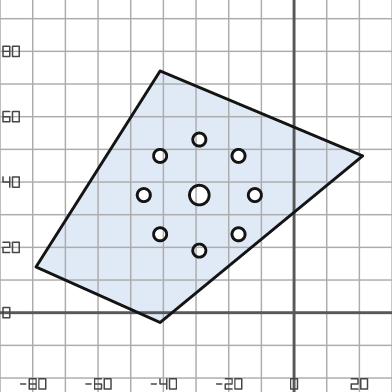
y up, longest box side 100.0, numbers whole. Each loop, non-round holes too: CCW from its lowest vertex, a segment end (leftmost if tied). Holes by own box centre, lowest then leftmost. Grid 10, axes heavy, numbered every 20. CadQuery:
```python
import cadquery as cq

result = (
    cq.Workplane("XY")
    .moveTo(-41.0, -3.0)
    .lineTo(21.0, 48.0)
    .lineTo(-41.0, 74.0)
    .lineTo(-79.0, 14.0)
    .close()
    .moveTo(-29.0, 19.0)
    .circle(2.0)
    .moveTo(-41.0, 24.0)
    .circle(2.0)
    .moveTo(-17.0, 24.0)
    .circle(2.0)
    .moveTo(-46.0, 36.0)
    .circle(2.0)
    .moveTo(-29.0, 36.0)
    .circle(3.0)
    .moveTo(-12.0, 36.0)
    .circle(2.0)
    .moveTo(-41.0, 48.0)
    .circle(2.0)
    .moveTo(-17.0, 48.0)
    .circle(2.0)
    .moveTo(-29.0, 53.0)
    .circle(2.0)
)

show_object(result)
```